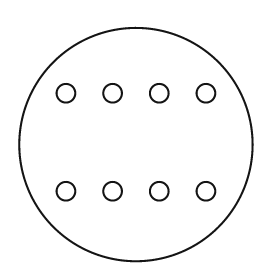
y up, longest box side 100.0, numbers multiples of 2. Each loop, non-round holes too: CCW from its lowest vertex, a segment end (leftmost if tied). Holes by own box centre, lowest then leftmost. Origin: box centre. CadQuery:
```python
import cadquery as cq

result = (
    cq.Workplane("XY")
    .moveTo(0.0, 0.0)
    .circle(50.0)
    .moveTo(-30.0, -20.0)
    .circle(4.0)
    .moveTo(-10.0, -20.0)
    .circle(4.0)
    .moveTo(10.0, -20.0)
    .circle(4.0)
    .moveTo(30.0, -20.0)
    .circle(4.0)
    .moveTo(-30.0, 22.0)
    .circle(4.0)
    .moveTo(-10.0, 22.0)
    .circle(4.0)
    .moveTo(10.0, 22.0)
    .circle(4.0)
    .moveTo(30.0, 22.0)
    .circle(4.0)
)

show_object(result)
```